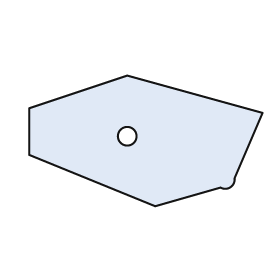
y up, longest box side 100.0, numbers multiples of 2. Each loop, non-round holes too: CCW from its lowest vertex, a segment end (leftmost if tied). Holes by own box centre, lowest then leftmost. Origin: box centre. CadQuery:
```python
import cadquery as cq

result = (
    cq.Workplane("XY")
    .moveTo(4.0, -28.0)
    .lineTo(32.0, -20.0)
    .threePointArc((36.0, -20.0), (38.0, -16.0))
    .lineTo(50.0, 12.0)
    .lineTo(-8.0, 28.0)
    .lineTo(-50.0, 14.0)
    .lineTo(-50.0, -6.0)
    .close()
    .moveTo(-8.0, 2.0)
    .circle(4.0)
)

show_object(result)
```